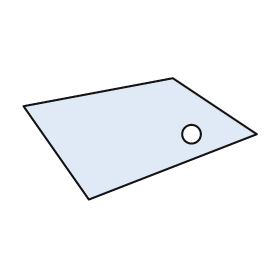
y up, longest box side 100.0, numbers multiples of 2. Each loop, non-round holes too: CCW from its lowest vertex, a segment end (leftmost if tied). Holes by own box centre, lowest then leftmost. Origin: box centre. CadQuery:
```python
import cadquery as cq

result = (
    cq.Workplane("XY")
    .moveTo(-22.0, -26.0)
    .lineTo(50.0, 2.0)
    .lineTo(14.0, 26.0)
    .lineTo(-50.0, 14.0)
    .close()
    .moveTo(22.0, 2.0)
    .circle(4.0)
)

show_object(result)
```